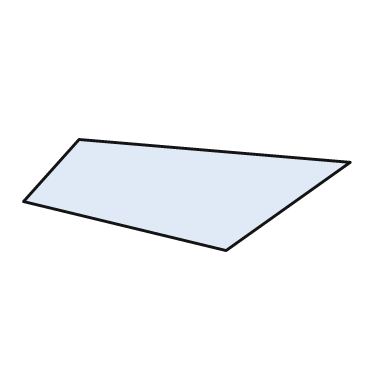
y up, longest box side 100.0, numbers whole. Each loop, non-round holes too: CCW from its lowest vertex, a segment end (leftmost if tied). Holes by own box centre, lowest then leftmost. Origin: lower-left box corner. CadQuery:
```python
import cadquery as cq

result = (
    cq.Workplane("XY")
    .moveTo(62.0, 0.0)
    .lineTo(100.0, 27.0)
    .lineTo(17.0, 34.0)
    .lineTo(0.0, 15.0)
    .close()
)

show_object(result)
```